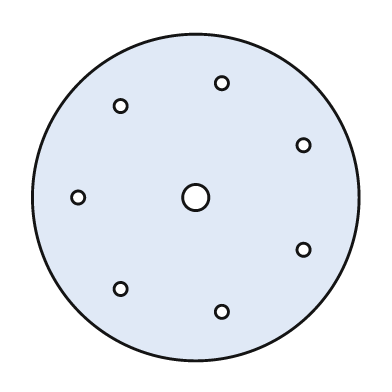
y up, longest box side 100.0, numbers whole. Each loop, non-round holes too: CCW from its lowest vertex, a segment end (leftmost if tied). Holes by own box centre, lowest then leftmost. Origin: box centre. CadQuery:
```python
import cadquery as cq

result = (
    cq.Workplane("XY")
    .moveTo(0.0, 0.0)
    .circle(50.0)
    .moveTo(8.0, -35.0)
    .circle(2.0)
    .moveTo(-23.0, -28.0)
    .circle(2.0)
    .moveTo(33.0, -16.0)
    .circle(2.0)
    .moveTo(-36.0, 0.0)
    .circle(2.0)
    .moveTo(0.0, 0.0)
    .circle(4.0)
    .moveTo(33.0, 16.0)
    .circle(2.0)
    .moveTo(-23.0, 28.0)
    .circle(2.0)
    .moveTo(8.0, 35.0)
    .circle(2.0)
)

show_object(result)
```